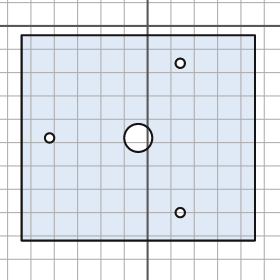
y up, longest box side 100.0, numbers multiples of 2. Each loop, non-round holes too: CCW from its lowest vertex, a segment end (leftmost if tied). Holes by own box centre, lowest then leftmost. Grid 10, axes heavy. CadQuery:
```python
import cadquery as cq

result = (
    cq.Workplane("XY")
    .moveTo(-54.0, -92.0)
    .lineTo(46.0, -92.0)
    .lineTo(46.0, -4.0)
    .lineTo(-54.0, -4.0)
    .close()
    .moveTo(14.0, -80.0)
    .circle(2.0)
    .moveTo(-42.0, -48.0)
    .circle(2.0)
    .moveTo(-4.0, -48.0)
    .circle(6.0)
    .moveTo(14.0, -16.0)
    .circle(2.0)
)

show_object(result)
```